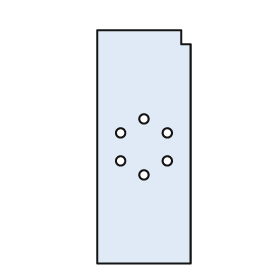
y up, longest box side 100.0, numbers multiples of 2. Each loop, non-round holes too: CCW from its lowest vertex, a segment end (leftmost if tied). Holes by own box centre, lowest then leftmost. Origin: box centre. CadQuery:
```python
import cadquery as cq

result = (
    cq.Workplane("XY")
    .moveTo(-20.0, -50.0)
    .lineTo(20.0, -50.0)
    .lineTo(20.0, 44.0)
    .lineTo(16.0, 44.0)
    .lineTo(16.0, 50.0)
    .lineTo(-20.0, 50.0)
    .close()
    .moveTo(0.0, -12.0)
    .circle(2.0)
    .moveTo(-10.0, -6.0)
    .circle(2.0)
    .moveTo(10.0, -6.0)
    .circle(2.0)
    .moveTo(-10.0, 6.0)
    .circle(2.0)
    .moveTo(10.0, 6.0)
    .circle(2.0)
    .moveTo(0.0, 12.0)
    .circle(2.0)
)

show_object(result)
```